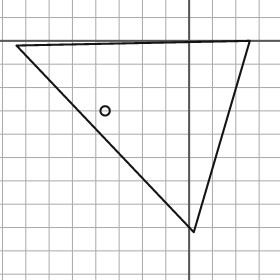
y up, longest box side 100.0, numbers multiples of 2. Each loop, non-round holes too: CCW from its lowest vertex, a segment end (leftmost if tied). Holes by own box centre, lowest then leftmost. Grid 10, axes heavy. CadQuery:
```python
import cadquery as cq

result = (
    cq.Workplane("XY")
    .moveTo(2.0, -82.0)
    .lineTo(26.0, 0.0)
    .lineTo(-74.0, -2.0)
    .close()
    .moveTo(-36.0, -30.0)
    .circle(2.0)
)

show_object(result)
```